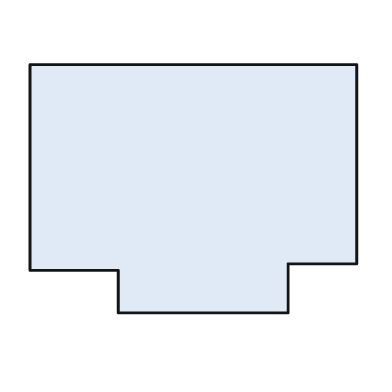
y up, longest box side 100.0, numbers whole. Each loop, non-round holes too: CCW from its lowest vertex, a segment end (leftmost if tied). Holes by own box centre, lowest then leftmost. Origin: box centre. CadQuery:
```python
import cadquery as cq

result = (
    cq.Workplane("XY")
    .moveTo(-23.0, -38.0)
    .lineTo(29.0, -38.0)
    .lineTo(29.0, -23.0)
    .lineTo(50.0, -23.0)
    .lineTo(50.0, 38.0)
    .lineTo(-50.0, 38.0)
    .lineTo(-50.0, -25.0)
    .lineTo(-23.0, -25.0)
    .close()
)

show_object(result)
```